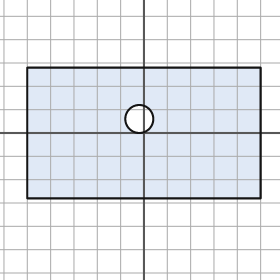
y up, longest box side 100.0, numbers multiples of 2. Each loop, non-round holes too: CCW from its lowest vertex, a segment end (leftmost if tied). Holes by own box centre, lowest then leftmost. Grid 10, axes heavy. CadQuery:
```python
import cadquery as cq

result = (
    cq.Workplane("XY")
    .moveTo(-50.0, -28.0)
    .lineTo(50.0, -28.0)
    .lineTo(50.0, 28.0)
    .lineTo(-50.0, 28.0)
    .close()
    .moveTo(-2.0, 6.0)
    .circle(6.0)
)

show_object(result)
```